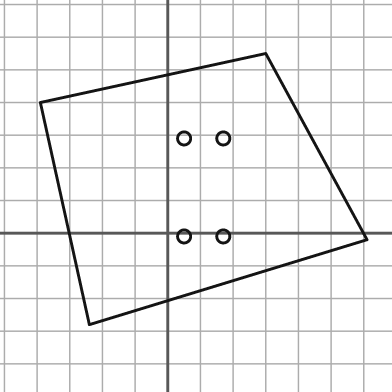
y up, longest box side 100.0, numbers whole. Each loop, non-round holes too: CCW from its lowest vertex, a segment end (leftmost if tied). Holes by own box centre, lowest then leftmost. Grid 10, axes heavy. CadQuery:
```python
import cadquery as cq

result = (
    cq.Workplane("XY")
    .moveTo(-24.0, -28.0)
    .lineTo(61.0, -2.0)
    .lineTo(30.0, 55.0)
    .lineTo(-39.0, 40.0)
    .close()
    .moveTo(5.0, -1.0)
    .circle(2.0)
    .moveTo(17.0, -1.0)
    .circle(2.0)
    .moveTo(5.0, 29.0)
    .circle(2.0)
    .moveTo(17.0, 29.0)
    .circle(2.0)
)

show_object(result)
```